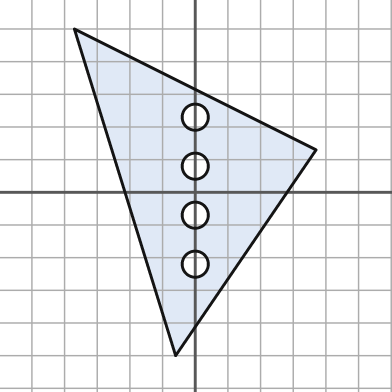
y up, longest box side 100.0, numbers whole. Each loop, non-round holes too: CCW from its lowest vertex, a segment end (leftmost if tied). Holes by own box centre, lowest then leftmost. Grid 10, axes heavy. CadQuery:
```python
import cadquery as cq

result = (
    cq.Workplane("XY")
    .moveTo(-6.0, -50.0)
    .lineTo(37.0, 13.0)
    .lineTo(-37.0, 50.0)
    .close()
    .moveTo(0.0, -22.0)
    .circle(4.0)
    .moveTo(0.0, -7.0)
    .circle(4.0)
    .moveTo(0.0, 8.0)
    .circle(4.0)
    .moveTo(0.0, 23.0)
    .circle(4.0)
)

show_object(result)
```